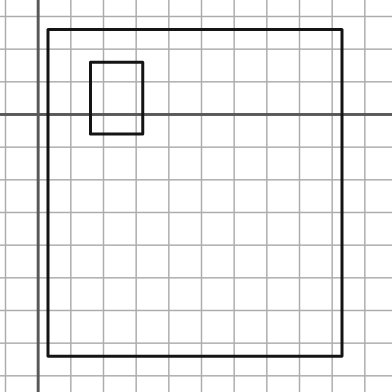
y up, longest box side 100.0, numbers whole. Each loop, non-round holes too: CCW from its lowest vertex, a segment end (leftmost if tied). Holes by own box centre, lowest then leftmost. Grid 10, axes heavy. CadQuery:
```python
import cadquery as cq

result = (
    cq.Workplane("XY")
    .moveTo(3.0, -74.0)
    .lineTo(93.0, -74.0)
    .lineTo(93.0, 26.0)
    .lineTo(3.0, 26.0)
    .close()
    .moveTo(16.0, -6.0)
    .lineTo(32.0, -6.0)
    .lineTo(32.0, 16.0)
    .lineTo(16.0, 16.0)
    .close()
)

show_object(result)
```